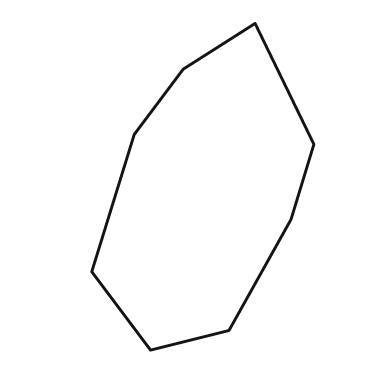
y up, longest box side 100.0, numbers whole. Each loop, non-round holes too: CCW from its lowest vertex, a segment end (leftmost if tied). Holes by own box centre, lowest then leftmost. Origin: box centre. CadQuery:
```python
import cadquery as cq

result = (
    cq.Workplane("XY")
    .moveTo(-16.0, -50.0)
    .lineTo(8.0, -44.0)
    .lineTo(27.0, -10.0)
    .lineTo(34.0, 13.0)
    .lineTo(16.0, 50.0)
    .lineTo(-6.0, 36.0)
    .lineTo(-21.0, 16.0)
    .lineTo(-34.0, -26.0)
    .close()
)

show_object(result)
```